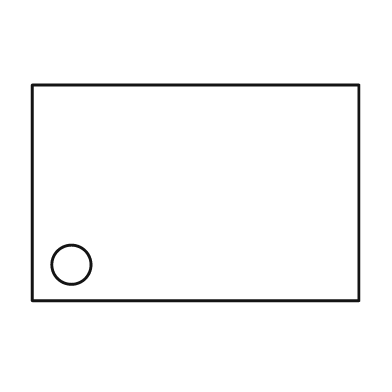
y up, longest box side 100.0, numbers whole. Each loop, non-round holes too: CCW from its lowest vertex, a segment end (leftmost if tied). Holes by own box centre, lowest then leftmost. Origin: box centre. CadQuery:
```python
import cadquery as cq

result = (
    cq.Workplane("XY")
    .moveTo(-50.0, -33.0)
    .lineTo(50.0, -33.0)
    .lineTo(50.0, 33.0)
    .lineTo(-50.0, 33.0)
    .close()
    .moveTo(-38.0, -22.0)
    .circle(6.0)
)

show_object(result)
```